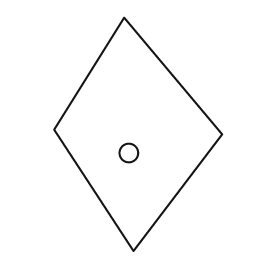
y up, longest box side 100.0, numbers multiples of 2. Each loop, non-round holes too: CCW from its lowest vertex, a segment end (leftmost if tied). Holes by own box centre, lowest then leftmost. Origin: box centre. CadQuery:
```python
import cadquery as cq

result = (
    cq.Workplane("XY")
    .moveTo(-2.0, -50.0)
    .lineTo(36.0, 0.0)
    .lineTo(-6.0, 50.0)
    .lineTo(-36.0, 2.0)
    .close()
    .moveTo(-4.0, -8.0)
    .circle(4.0)
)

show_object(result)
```